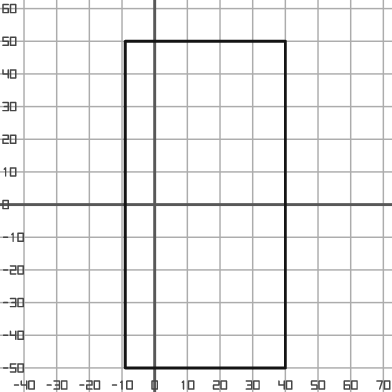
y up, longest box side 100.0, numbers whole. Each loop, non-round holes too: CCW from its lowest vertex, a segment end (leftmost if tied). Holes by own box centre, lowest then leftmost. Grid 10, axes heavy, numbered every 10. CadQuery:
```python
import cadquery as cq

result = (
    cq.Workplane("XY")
    .moveTo(-9.0, -50.0)
    .lineTo(40.0, -50.0)
    .lineTo(40.0, 50.0)
    .lineTo(-9.0, 50.0)
    .close()
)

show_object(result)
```